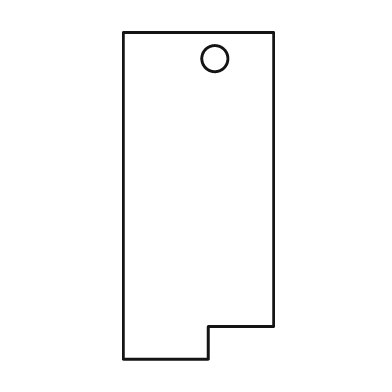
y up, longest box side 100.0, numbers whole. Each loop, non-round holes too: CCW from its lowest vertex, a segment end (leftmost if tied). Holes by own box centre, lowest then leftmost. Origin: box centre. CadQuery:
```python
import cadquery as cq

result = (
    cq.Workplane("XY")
    .moveTo(-23.0, -50.0)
    .lineTo(3.0, -50.0)
    .lineTo(3.0, -40.0)
    .lineTo(23.0, -40.0)
    .lineTo(23.0, 50.0)
    .lineTo(-23.0, 50.0)
    .close()
    .moveTo(5.0, 42.0)
    .circle(4.0)
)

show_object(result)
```